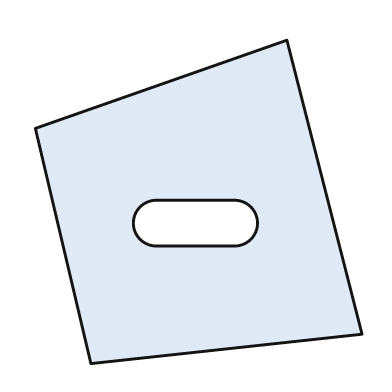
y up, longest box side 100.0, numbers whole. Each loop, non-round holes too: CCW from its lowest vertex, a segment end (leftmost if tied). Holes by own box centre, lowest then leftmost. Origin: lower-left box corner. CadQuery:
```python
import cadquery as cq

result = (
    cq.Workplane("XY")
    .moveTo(17.0, 0.0)
    .lineTo(100.0, 9.0)
    .lineTo(77.0, 99.0)
    .lineTo(0.0, 72.0)
    .close()
    .moveTo(37.0, 36.0)
    .lineTo(61.0, 36.0)
    .threePointArc((68.0, 43.0), (61.0, 50.0))
    .lineTo(37.0, 50.0)
    .threePointArc((30.0, 43.0), (37.0, 36.0))
    .close()
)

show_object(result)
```